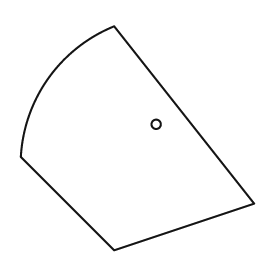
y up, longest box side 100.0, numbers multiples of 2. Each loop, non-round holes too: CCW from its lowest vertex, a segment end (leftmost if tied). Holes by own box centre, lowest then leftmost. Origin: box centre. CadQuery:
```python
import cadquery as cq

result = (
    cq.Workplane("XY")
    .moveTo(-10.0, -48.0)
    .lineTo(50.0, -28.0)
    .lineTo(-10.0, 48.0)
    .threePointArc((-38.0, 26.0), (-50.0, -8.0))
    .close()
    .moveTo(8.0, 6.0)
    .circle(2.0)
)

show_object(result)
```